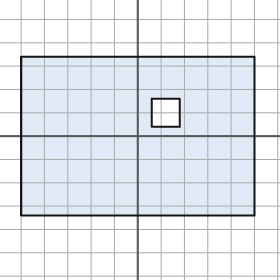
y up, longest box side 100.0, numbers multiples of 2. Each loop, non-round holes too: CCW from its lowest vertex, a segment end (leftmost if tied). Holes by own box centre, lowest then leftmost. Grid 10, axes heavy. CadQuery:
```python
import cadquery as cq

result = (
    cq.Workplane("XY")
    .moveTo(-50.0, -34.0)
    .lineTo(50.0, -34.0)
    .lineTo(50.0, 34.0)
    .lineTo(-50.0, 34.0)
    .close()
    .moveTo(6.0, 4.0)
    .lineTo(18.0, 4.0)
    .lineTo(18.0, 16.0)
    .lineTo(6.0, 16.0)
    .close()
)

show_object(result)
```